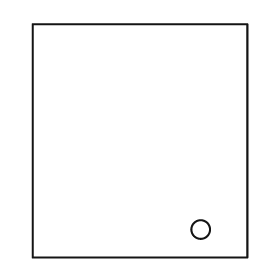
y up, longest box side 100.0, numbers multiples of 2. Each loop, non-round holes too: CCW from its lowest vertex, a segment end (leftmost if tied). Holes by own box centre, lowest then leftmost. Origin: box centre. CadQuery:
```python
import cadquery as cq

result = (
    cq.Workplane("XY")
    .moveTo(-46.0, -50.0)
    .lineTo(46.0, -50.0)
    .lineTo(46.0, 50.0)
    .lineTo(-46.0, 50.0)
    .close()
    .moveTo(26.0, -38.0)
    .circle(4.0)
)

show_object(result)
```